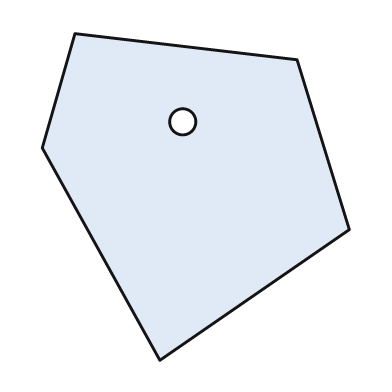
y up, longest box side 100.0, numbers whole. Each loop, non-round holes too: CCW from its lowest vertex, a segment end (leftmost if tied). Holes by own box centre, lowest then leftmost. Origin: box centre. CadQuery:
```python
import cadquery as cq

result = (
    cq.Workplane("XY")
    .moveTo(-11.0, -50.0)
    .lineTo(47.0, -10.0)
    .lineTo(31.0, 42.0)
    .lineTo(-37.0, 50.0)
    .lineTo(-47.0, 15.0)
    .close()
    .moveTo(-4.0, 23.0)
    .circle(4.0)
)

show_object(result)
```